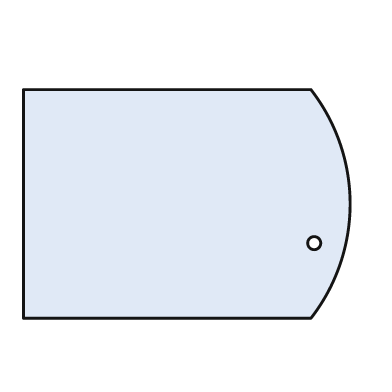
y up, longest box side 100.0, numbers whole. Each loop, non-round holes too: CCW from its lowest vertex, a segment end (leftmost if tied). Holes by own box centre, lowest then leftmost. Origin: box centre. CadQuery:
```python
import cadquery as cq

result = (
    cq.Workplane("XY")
    .moveTo(-50.0, -35.0)
    .lineTo(38.0, -35.0)
    .threePointArc((50.0, 0.0), (38.0, 35.0))
    .lineTo(-50.0, 35.0)
    .close()
    .moveTo(39.0, -12.0)
    .circle(2.0)
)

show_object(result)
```